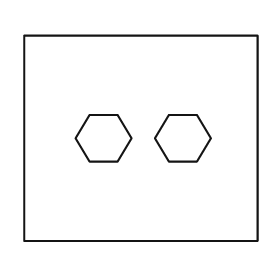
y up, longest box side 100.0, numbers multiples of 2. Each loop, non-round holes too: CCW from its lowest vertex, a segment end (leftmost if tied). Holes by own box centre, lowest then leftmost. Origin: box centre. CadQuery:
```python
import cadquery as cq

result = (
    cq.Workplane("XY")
    .moveTo(-50.0, -44.0)
    .lineTo(50.0, -44.0)
    .lineTo(50.0, 44.0)
    .lineTo(-50.0, 44.0)
    .close()
    .moveTo(-22.0, -10.0)
    .lineTo(-10.0, -10.0)
    .lineTo(-4.0, 0.0)
    .lineTo(-10.0, 10.0)
    .lineTo(-22.0, 10.0)
    .lineTo(-28.0, 0.0)
    .close()
    .moveTo(12.0, -10.0)
    .lineTo(24.0, -10.0)
    .lineTo(30.0, 0.0)
    .lineTo(24.0, 10.0)
    .lineTo(12.0, 10.0)
    .lineTo(6.0, 0.0)
    .close()
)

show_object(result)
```